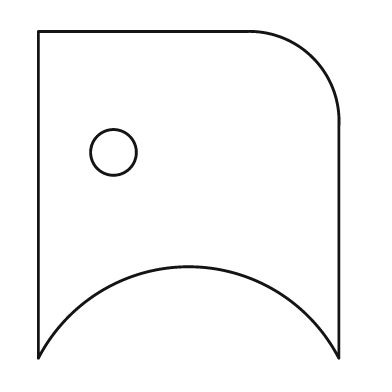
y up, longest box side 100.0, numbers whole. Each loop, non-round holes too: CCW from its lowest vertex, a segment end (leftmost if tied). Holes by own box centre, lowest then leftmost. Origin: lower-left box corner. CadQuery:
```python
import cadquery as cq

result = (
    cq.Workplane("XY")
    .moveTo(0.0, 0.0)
    .threePointArc((46.0, 28.0), (92.0, 0.0))
    .lineTo(92.0, 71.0)
    .threePointArc((84.0, 92.0), (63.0, 100.0))
    .lineTo(0.0, 100.0)
    .close()
    .moveTo(23.0, 63.0)
    .circle(7.0)
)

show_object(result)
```